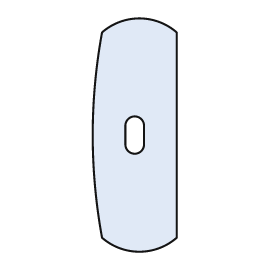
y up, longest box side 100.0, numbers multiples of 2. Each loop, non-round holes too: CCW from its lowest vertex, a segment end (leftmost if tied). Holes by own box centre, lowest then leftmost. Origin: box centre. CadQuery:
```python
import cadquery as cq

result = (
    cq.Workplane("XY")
    .moveTo(-14.0, -44.0)
    .threePointArc((2.0, -50.0), (18.0, -44.0))
    .lineTo(18.0, 44.0)
    .threePointArc((2.0, 50.0), (-14.0, 44.0))
    .threePointArc((-18.0, 0.0), (-14.0, -44.0))
    .close()
    .moveTo(-4.0, -4.0)
    .threePointArc((0.0, -8.0), (4.0, -4.0))
    .lineTo(4.0, 4.0)
    .threePointArc((0.0, 8.0), (-4.0, 4.0))
    .close()
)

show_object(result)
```